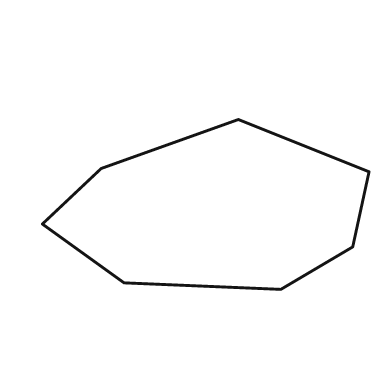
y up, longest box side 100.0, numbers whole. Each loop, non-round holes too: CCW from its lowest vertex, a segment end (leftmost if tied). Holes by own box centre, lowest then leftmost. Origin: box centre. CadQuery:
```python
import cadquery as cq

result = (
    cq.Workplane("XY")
    .moveTo(23.0, -26.0)
    .lineTo(45.0, -13.0)
    .lineTo(50.0, 10.0)
    .lineTo(10.0, 26.0)
    .lineTo(-32.0, 11.0)
    .lineTo(-50.0, -6.0)
    .lineTo(-25.0, -24.0)
    .close()
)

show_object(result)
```